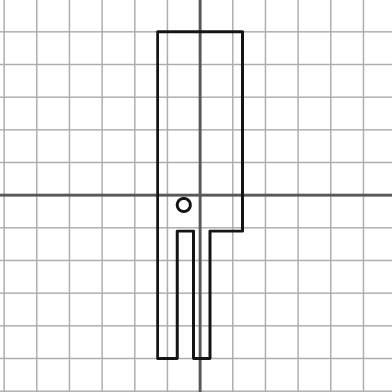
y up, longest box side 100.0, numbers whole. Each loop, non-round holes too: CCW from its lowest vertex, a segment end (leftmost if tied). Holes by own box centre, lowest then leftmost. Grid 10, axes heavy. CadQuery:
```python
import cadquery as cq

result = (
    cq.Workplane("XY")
    .moveTo(-13.0, -50.0)
    .lineTo(-7.0, -50.0)
    .lineTo(-7.0, -11.0)
    .lineTo(-2.0, -11.0)
    .lineTo(-2.0, -50.0)
    .lineTo(3.0, -50.0)
    .lineTo(3.0, -11.0)
    .lineTo(13.0, -11.0)
    .lineTo(13.0, 50.0)
    .lineTo(-13.0, 50.0)
    .close()
    .moveTo(-5.0, -3.0)
    .circle(2.0)
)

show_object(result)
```